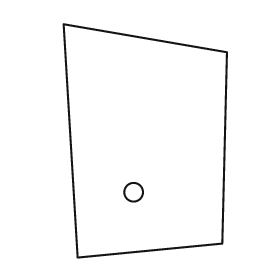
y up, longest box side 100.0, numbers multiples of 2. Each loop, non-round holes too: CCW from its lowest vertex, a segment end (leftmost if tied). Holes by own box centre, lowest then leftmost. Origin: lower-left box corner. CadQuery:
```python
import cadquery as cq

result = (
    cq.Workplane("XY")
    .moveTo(6.0, 0.0)
    .lineTo(68.0, 6.0)
    .lineTo(70.0, 88.0)
    .lineTo(0.0, 100.0)
    .close()
    .moveTo(30.0, 28.0)
    .circle(4.0)
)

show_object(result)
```